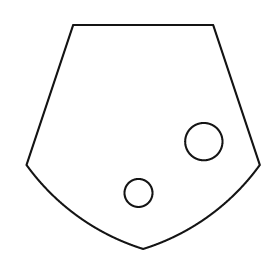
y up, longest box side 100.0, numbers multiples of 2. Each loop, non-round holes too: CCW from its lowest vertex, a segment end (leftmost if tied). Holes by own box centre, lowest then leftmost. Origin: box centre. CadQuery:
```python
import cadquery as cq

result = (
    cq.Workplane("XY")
    .moveTo(0.0, -48.0)
    .threePointArc((28.0, -34.0), (50.0, -12.0))
    .lineTo(30.0, 48.0)
    .lineTo(-30.0, 48.0)
    .lineTo(-50.0, -12.0)
    .threePointArc((-28.0, -34.0), (0.0, -48.0))
    .close()
    .moveTo(-2.0, -24.0)
    .circle(6.0)
    .moveTo(26.0, -2.0)
    .circle(8.0)
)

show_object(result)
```